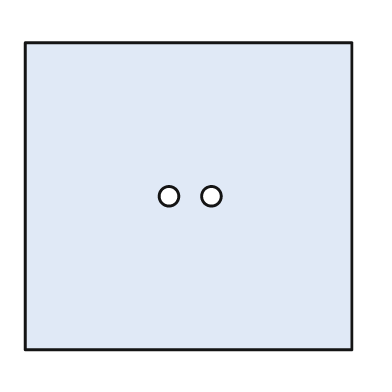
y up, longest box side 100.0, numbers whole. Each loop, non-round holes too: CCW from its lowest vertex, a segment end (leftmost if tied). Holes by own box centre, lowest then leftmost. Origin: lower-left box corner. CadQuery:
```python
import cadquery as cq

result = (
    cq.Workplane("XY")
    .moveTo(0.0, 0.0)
    .lineTo(100.0, 0.0)
    .lineTo(100.0, 94.0)
    .lineTo(0.0, 94.0)
    .close()
    .moveTo(44.0, 47.0)
    .circle(3.0)
    .moveTo(57.0, 47.0)
    .circle(3.0)
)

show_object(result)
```